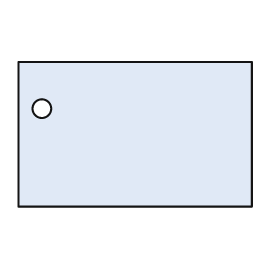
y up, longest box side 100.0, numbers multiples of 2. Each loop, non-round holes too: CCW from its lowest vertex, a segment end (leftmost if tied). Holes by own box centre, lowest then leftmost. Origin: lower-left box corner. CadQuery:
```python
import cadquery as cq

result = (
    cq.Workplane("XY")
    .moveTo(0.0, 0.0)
    .lineTo(100.0, 0.0)
    .lineTo(100.0, 62.0)
    .lineTo(0.0, 62.0)
    .close()
    .moveTo(10.0, 42.0)
    .circle(4.0)
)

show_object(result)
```